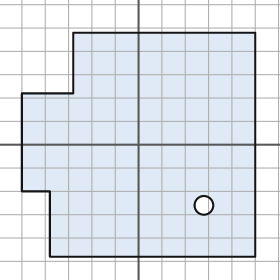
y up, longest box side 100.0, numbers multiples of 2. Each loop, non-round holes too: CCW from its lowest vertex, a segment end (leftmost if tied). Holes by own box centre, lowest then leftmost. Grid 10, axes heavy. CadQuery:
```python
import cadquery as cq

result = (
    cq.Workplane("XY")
    .moveTo(-38.0, -48.0)
    .lineTo(50.0, -48.0)
    .lineTo(50.0, 48.0)
    .lineTo(-28.0, 48.0)
    .lineTo(-28.0, 22.0)
    .lineTo(-50.0, 22.0)
    .lineTo(-50.0, -20.0)
    .lineTo(-38.0, -20.0)
    .close()
    .moveTo(28.0, -26.0)
    .circle(4.0)
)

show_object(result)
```